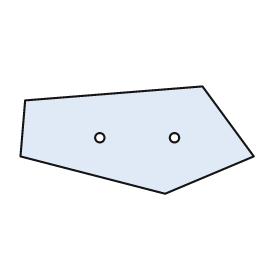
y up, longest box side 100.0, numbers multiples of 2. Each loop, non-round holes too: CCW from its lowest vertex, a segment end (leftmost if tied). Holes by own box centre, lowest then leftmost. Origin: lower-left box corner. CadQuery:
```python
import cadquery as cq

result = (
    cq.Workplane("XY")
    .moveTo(62.0, 0.0)
    .lineTo(100.0, 16.0)
    .lineTo(78.0, 46.0)
    .lineTo(2.0, 40.0)
    .lineTo(0.0, 16.0)
    .close()
    .moveTo(34.0, 24.0)
    .circle(2.0)
    .moveTo(66.0, 24.0)
    .circle(2.0)
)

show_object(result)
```